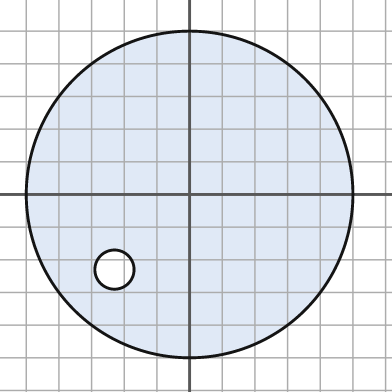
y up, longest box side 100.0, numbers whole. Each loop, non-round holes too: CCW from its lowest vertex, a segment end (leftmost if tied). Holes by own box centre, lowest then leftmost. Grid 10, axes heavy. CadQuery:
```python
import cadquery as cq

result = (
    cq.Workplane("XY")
    .moveTo(0.0, 0.0)
    .circle(50.0)
    .moveTo(-23.0, -23.0)
    .circle(6.0)
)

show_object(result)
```